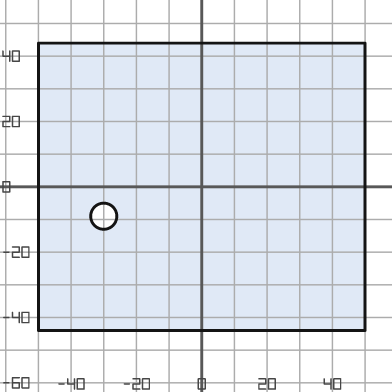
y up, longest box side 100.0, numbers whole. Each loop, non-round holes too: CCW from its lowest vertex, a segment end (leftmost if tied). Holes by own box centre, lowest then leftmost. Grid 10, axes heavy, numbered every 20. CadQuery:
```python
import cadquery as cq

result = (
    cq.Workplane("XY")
    .moveTo(-50.0, -44.0)
    .lineTo(50.0, -44.0)
    .lineTo(50.0, 44.0)
    .lineTo(-50.0, 44.0)
    .close()
    .moveTo(-30.0, -9.0)
    .circle(4.0)
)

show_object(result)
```